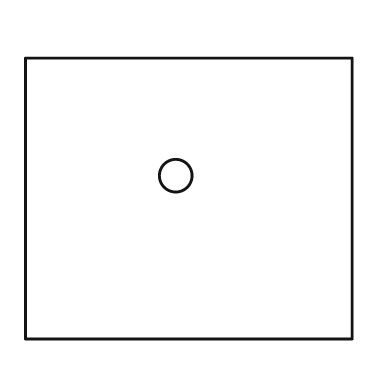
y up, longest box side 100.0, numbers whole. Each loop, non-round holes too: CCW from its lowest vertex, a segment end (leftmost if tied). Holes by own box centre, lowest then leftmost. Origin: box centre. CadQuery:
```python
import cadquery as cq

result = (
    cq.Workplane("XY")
    .moveTo(-50.0, -43.0)
    .lineTo(50.0, -43.0)
    .lineTo(50.0, 43.0)
    .lineTo(-50.0, 43.0)
    .close()
    .moveTo(-4.0, 7.0)
    .circle(5.0)
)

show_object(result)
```